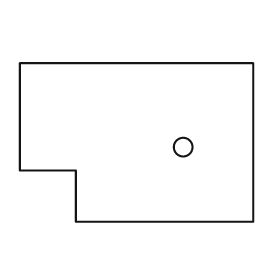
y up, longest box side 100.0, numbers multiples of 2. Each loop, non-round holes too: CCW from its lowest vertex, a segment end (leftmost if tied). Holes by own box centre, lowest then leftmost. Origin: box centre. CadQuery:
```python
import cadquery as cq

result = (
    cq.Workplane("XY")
    .moveTo(-26.0, -34.0)
    .lineTo(50.0, -34.0)
    .lineTo(50.0, 34.0)
    .lineTo(-50.0, 34.0)
    .lineTo(-50.0, -12.0)
    .lineTo(-26.0, -12.0)
    .close()
    .moveTo(20.0, -2.0)
    .circle(4.0)
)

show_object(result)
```